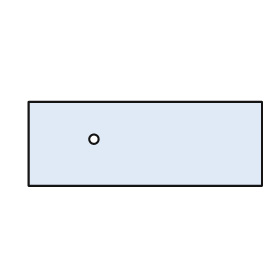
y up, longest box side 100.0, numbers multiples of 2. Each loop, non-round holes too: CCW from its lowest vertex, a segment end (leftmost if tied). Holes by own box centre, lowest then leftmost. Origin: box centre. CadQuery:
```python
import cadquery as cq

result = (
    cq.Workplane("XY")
    .moveTo(-50.0, -18.0)
    .lineTo(50.0, -18.0)
    .lineTo(50.0, 18.0)
    .lineTo(-50.0, 18.0)
    .close()
    .moveTo(-22.0, 2.0)
    .circle(2.0)
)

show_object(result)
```